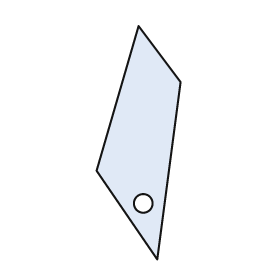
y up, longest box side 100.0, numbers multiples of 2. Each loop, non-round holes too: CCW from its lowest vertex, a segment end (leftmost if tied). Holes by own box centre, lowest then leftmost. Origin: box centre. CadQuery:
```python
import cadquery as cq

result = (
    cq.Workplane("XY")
    .moveTo(8.0, -50.0)
    .lineTo(18.0, 26.0)
    .lineTo(0.0, 50.0)
    .lineTo(-18.0, -12.0)
    .close()
    .moveTo(2.0, -26.0)
    .circle(4.0)
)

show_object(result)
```